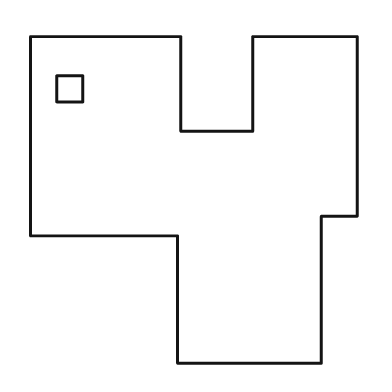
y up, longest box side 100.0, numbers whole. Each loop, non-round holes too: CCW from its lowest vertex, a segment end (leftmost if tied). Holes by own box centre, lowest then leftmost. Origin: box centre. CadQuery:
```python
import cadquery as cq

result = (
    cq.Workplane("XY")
    .moveTo(-5.0, -50.0)
    .lineTo(39.0, -50.0)
    .lineTo(39.0, -5.0)
    .lineTo(50.0, -5.0)
    .lineTo(50.0, 50.0)
    .lineTo(18.0, 50.0)
    .lineTo(18.0, 21.0)
    .lineTo(-4.0, 21.0)
    .lineTo(-4.0, 50.0)
    .lineTo(-50.0, 50.0)
    .lineTo(-50.0, -11.0)
    .lineTo(-5.0, -11.0)
    .close()
    .moveTo(-42.0, 30.0)
    .lineTo(-34.0, 30.0)
    .lineTo(-34.0, 38.0)
    .lineTo(-42.0, 38.0)
    .close()
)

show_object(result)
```